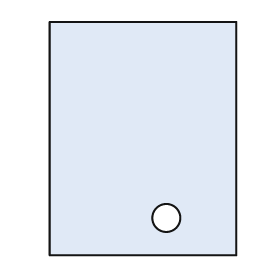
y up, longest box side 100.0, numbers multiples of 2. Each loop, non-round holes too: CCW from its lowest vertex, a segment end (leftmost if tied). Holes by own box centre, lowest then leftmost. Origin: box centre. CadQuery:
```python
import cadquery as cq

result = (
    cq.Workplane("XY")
    .moveTo(-40.0, -50.0)
    .lineTo(40.0, -50.0)
    .lineTo(40.0, 50.0)
    .lineTo(-40.0, 50.0)
    .close()
    .moveTo(10.0, -34.0)
    .circle(6.0)
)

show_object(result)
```